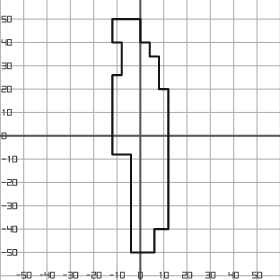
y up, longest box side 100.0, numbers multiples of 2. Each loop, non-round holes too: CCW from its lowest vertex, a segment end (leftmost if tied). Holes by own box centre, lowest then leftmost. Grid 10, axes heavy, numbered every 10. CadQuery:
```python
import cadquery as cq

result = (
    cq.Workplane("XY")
    .moveTo(-4.0, -50.0)
    .lineTo(6.0, -50.0)
    .lineTo(6.0, -40.0)
    .lineTo(12.0, -40.0)
    .lineTo(12.0, 20.0)
    .lineTo(8.0, 20.0)
    .lineTo(8.0, 34.0)
    .lineTo(4.0, 34.0)
    .lineTo(4.0, 40.0)
    .lineTo(0.0, 40.0)
    .lineTo(0.0, 50.0)
    .lineTo(-12.0, 50.0)
    .lineTo(-12.0, 40.0)
    .lineTo(-8.0, 40.0)
    .lineTo(-8.0, 26.0)
    .lineTo(-12.0, 26.0)
    .lineTo(-12.0, -8.0)
    .lineTo(-4.0, -8.0)
    .close()
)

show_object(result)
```